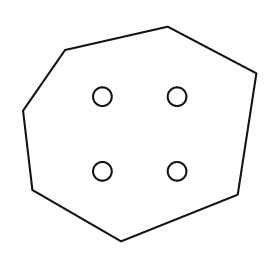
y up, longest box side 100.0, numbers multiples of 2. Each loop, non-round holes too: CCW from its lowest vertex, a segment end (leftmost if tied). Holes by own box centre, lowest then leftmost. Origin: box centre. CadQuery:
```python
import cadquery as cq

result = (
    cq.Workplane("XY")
    .moveTo(-8.0, -46.0)
    .lineTo(42.0, -26.0)
    .lineTo(50.0, 26.0)
    .lineTo(12.0, 46.0)
    .lineTo(-32.0, 36.0)
    .lineTo(-50.0, 10.0)
    .lineTo(-46.0, -24.0)
    .close()
    .moveTo(-16.0, -16.0)
    .circle(4.0)
    .moveTo(16.0, -16.0)
    .circle(4.0)
    .moveTo(-16.0, 16.0)
    .circle(4.0)
    .moveTo(16.0, 16.0)
    .circle(4.0)
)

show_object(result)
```